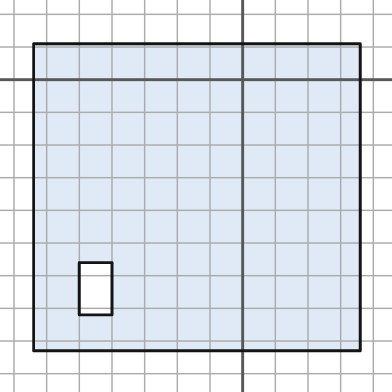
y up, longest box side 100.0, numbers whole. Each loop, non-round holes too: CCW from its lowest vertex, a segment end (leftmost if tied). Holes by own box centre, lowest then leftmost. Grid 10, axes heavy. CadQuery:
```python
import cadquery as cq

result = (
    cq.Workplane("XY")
    .moveTo(-64.0, -83.0)
    .lineTo(36.0, -83.0)
    .lineTo(36.0, 11.0)
    .lineTo(-64.0, 11.0)
    .close()
    .moveTo(-50.0, -72.0)
    .lineTo(-40.0, -72.0)
    .lineTo(-40.0, -56.0)
    .lineTo(-50.0, -56.0)
    .close()
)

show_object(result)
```